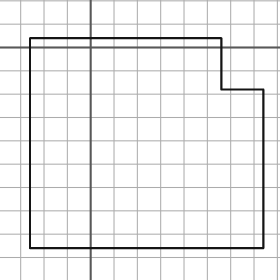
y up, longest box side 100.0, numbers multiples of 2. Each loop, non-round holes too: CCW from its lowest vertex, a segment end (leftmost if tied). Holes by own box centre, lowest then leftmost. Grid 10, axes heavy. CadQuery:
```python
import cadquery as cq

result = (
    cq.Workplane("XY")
    .moveTo(-26.0, -86.0)
    .lineTo(74.0, -86.0)
    .lineTo(74.0, -18.0)
    .lineTo(56.0, -18.0)
    .lineTo(56.0, 4.0)
    .lineTo(-26.0, 4.0)
    .close()
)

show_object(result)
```